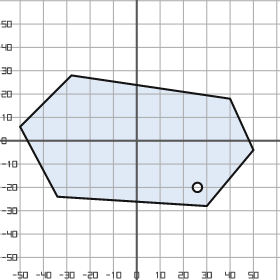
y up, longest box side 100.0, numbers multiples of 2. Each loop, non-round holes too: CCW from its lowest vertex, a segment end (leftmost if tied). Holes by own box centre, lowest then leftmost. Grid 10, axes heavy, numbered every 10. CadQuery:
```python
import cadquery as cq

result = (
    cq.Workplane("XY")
    .moveTo(30.0, -28.0)
    .lineTo(50.0, -4.0)
    .lineTo(40.0, 18.0)
    .lineTo(-28.0, 28.0)
    .lineTo(-50.0, 6.0)
    .lineTo(-34.0, -24.0)
    .close()
    .moveTo(26.0, -20.0)
    .circle(2.0)
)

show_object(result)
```